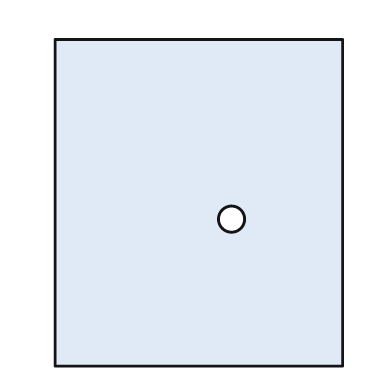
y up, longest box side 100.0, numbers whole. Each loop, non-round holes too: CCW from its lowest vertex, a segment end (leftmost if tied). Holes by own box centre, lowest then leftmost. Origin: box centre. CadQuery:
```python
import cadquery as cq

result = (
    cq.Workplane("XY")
    .moveTo(-44.0, -50.0)
    .lineTo(44.0, -50.0)
    .lineTo(44.0, 50.0)
    .lineTo(-44.0, 50.0)
    .close()
    .moveTo(10.0, -5.0)
    .circle(4.0)
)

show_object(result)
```